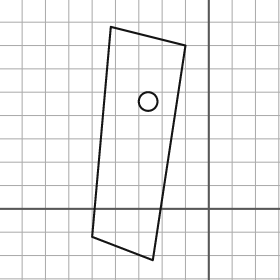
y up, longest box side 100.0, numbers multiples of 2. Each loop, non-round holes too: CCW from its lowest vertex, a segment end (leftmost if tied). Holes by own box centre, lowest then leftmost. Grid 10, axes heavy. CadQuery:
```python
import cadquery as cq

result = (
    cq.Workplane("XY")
    .moveTo(-24.0, -22.0)
    .lineTo(-10.0, 70.0)
    .lineTo(-42.0, 78.0)
    .lineTo(-50.0, -12.0)
    .close()
    .moveTo(-26.0, 46.0)
    .circle(4.0)
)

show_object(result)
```